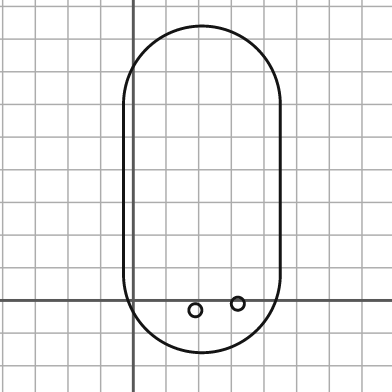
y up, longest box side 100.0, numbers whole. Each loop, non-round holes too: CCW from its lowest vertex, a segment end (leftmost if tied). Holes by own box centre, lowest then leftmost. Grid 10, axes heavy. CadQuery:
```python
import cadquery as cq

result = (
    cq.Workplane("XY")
    .moveTo(-3.0, 8.0)
    .threePointArc((21.0, -16.0), (45.0, 8.0))
    .lineTo(45.0, 60.0)
    .threePointArc((21.0, 84.0), (-3.0, 60.0))
    .close()
    .moveTo(19.0, -3.0)
    .circle(2.0)
    .moveTo(32.0, -1.0)
    .circle(2.0)
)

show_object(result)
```